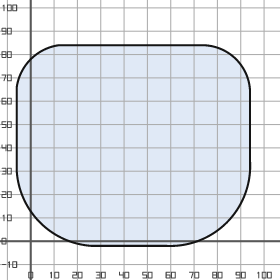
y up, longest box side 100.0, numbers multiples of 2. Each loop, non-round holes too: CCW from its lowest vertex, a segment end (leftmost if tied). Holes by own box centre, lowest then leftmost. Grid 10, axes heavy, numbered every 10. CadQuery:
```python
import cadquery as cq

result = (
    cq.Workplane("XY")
    .moveTo(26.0, -2.0)
    .lineTo(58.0, -2.0)
    .threePointArc((84.0, 8.0), (94.0, 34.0))
    .lineTo(94.0, 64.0)
    .threePointArc((88.0, 78.0), (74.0, 84.0))
    .lineTo(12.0, 84.0)
    .threePointArc((0.0, 78.0), (-6.0, 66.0))
    .lineTo(-6.0, 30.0)
    .threePointArc((4.0, 8.0), (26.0, -2.0))
    .close()
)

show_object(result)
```